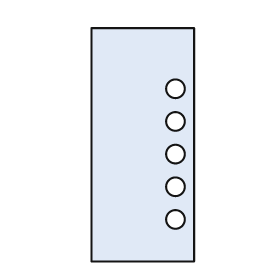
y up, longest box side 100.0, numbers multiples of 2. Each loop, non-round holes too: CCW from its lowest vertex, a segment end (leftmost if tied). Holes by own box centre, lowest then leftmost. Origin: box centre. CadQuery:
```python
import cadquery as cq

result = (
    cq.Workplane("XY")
    .moveTo(-22.0, -50.0)
    .lineTo(22.0, -50.0)
    .lineTo(22.0, 50.0)
    .lineTo(-22.0, 50.0)
    .close()
    .moveTo(14.0, -32.0)
    .circle(4.0)
    .moveTo(14.0, -18.0)
    .circle(4.0)
    .moveTo(14.0, -4.0)
    .circle(4.0)
    .moveTo(14.0, 10.0)
    .circle(4.0)
    .moveTo(14.0, 24.0)
    .circle(4.0)
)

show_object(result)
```